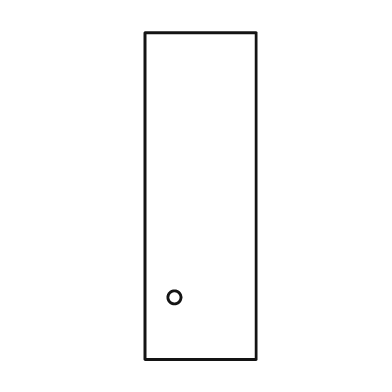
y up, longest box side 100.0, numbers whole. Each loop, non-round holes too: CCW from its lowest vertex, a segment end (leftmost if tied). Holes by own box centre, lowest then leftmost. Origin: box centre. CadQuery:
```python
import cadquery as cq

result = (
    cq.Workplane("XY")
    .moveTo(-17.0, -50.0)
    .lineTo(17.0, -50.0)
    .lineTo(17.0, 50.0)
    .lineTo(-17.0, 50.0)
    .close()
    .moveTo(-8.0, -31.0)
    .circle(2.0)
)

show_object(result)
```